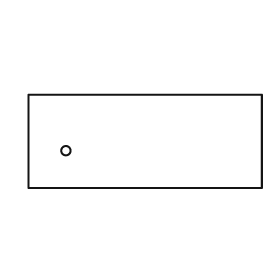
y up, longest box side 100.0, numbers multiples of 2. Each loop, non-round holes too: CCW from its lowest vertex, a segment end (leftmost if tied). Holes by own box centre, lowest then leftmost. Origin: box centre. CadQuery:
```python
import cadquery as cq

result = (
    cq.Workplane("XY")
    .moveTo(-50.0, -20.0)
    .lineTo(50.0, -20.0)
    .lineTo(50.0, 20.0)
    .lineTo(-50.0, 20.0)
    .close()
    .moveTo(-34.0, -4.0)
    .circle(2.0)
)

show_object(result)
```